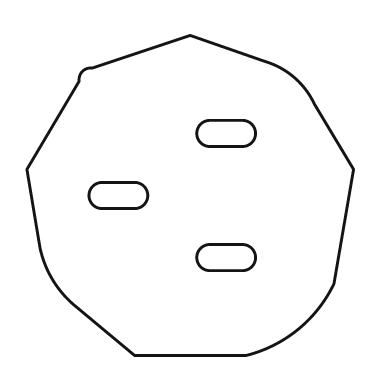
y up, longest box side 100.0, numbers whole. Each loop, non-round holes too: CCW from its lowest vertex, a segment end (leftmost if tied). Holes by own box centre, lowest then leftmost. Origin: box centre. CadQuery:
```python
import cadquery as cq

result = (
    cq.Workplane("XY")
    .moveTo(-17.0, -49.0)
    .lineTo(17.0, -49.0)
    .threePointArc((33.0, -41.0), (44.0, -27.0))
    .lineTo(50.0, 8.0)
    .lineTo(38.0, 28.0)
    .threePointArc((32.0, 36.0), (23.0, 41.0))
    .lineTo(0.0, 49.0)
    .lineTo(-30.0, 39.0)
    .threePointArc((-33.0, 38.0), (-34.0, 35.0))
    .lineTo(-50.0, 8.0)
    .lineTo(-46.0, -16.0)
    .threePointArc((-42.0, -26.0), (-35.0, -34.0))
    .close()
    .moveTo(6.0, -23.0)
    .lineTo(16.0, -23.0)
    .threePointArc((20.0, -19.0), (16.0, -15.0))
    .lineTo(6.0, -15.0)
    .threePointArc((2.0, -19.0), (6.0, -23.0))
    .close()
    .moveTo(-27.0, -4.0)
    .lineTo(-17.0, -4.0)
    .threePointArc((-13.0, 0.0), (-17.0, 4.0))
    .lineTo(-27.0, 4.0)
    .threePointArc((-31.0, 0.0), (-27.0, -4.0))
    .close()
    .moveTo(6.0, 15.0)
    .lineTo(16.0, 15.0)
    .threePointArc((20.0, 19.0), (16.0, 23.0))
    .lineTo(6.0, 23.0)
    .threePointArc((2.0, 19.0), (6.0, 15.0))
    .close()
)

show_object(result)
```